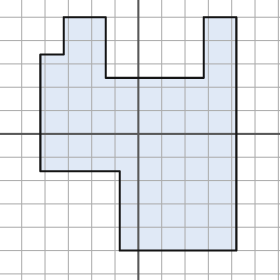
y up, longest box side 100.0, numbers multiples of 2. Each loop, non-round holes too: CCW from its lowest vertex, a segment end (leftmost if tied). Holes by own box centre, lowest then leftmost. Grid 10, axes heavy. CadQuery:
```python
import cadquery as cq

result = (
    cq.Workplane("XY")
    .moveTo(-8.0, -50.0)
    .lineTo(42.0, -50.0)
    .lineTo(42.0, 50.0)
    .lineTo(28.0, 50.0)
    .lineTo(28.0, 24.0)
    .lineTo(-14.0, 24.0)
    .lineTo(-14.0, 50.0)
    .lineTo(-32.0, 50.0)
    .lineTo(-32.0, 34.0)
    .lineTo(-42.0, 34.0)
    .lineTo(-42.0, -16.0)
    .lineTo(-8.0, -16.0)
    .close()
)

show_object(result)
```